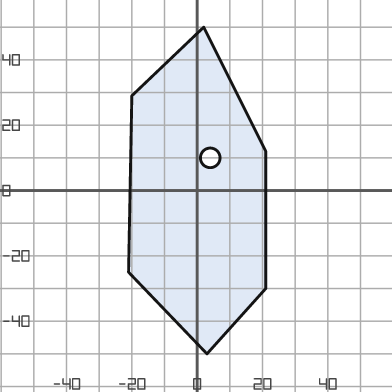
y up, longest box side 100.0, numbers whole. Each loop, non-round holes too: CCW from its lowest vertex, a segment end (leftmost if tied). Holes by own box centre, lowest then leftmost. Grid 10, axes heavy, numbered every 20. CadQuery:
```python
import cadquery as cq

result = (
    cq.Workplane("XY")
    .moveTo(3.0, -50.0)
    .lineTo(21.0, -30.0)
    .lineTo(21.0, 12.0)
    .lineTo(2.0, 50.0)
    .lineTo(-20.0, 29.0)
    .lineTo(-21.0, -25.0)
    .close()
    .moveTo(4.0, 10.0)
    .circle(3.0)
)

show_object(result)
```